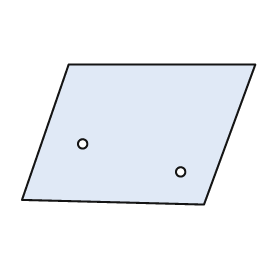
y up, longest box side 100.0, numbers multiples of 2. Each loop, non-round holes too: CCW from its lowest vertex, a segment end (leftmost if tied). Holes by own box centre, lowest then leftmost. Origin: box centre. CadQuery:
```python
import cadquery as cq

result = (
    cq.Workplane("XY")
    .moveTo(28.0, -30.0)
    .lineTo(50.0, 30.0)
    .lineTo(-30.0, 30.0)
    .lineTo(-50.0, -28.0)
    .close()
    .moveTo(18.0, -16.0)
    .circle(2.0)
    .moveTo(-24.0, -4.0)
    .circle(2.0)
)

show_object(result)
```